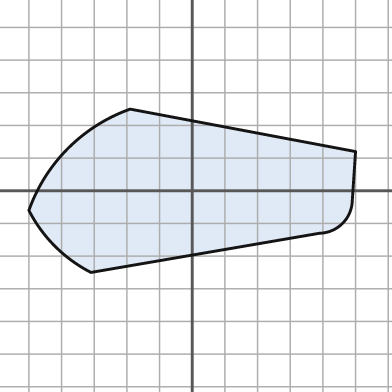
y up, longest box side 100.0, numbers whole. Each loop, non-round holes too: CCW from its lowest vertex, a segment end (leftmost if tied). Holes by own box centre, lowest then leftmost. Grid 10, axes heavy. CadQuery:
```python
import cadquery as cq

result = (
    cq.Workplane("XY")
    .moveTo(-31.0, -25.0)
    .lineTo(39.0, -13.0)
    .threePointArc((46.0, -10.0), (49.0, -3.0))
    .lineTo(50.0, 12.0)
    .lineTo(-19.0, 25.0)
    .threePointArc((-38.0, 13.0), (-50.0, -6.0))
    .threePointArc((-42.0, -17.0), (-31.0, -25.0))
    .close()
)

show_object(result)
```